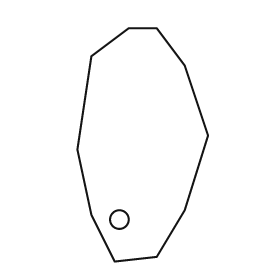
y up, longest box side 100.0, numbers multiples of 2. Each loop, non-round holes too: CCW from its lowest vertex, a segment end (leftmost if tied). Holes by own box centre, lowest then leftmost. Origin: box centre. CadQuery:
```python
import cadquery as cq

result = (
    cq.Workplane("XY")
    .moveTo(-12.0, -50.0)
    .lineTo(6.0, -48.0)
    .lineTo(18.0, -28.0)
    .lineTo(28.0, 4.0)
    .lineTo(18.0, 34.0)
    .lineTo(6.0, 50.0)
    .lineTo(-6.0, 50.0)
    .lineTo(-22.0, 38.0)
    .lineTo(-28.0, -2.0)
    .lineTo(-22.0, -30.0)
    .close()
    .moveTo(-10.0, -32.0)
    .circle(4.0)
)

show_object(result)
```